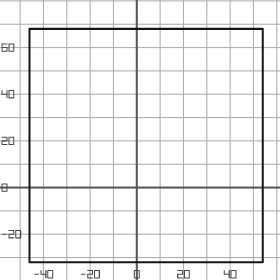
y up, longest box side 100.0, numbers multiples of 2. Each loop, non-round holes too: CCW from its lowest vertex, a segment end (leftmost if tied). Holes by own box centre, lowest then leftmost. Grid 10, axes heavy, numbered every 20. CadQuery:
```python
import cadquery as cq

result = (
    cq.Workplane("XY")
    .moveTo(-46.0, -32.0)
    .lineTo(54.0, -32.0)
    .lineTo(54.0, 68.0)
    .lineTo(-46.0, 68.0)
    .close()
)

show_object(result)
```